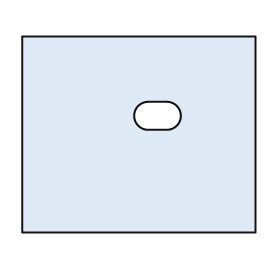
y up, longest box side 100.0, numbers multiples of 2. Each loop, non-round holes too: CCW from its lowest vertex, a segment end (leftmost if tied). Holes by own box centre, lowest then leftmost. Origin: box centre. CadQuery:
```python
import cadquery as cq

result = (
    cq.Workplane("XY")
    .moveTo(-50.0, -42.0)
    .lineTo(50.0, -42.0)
    .lineTo(50.0, 42.0)
    .lineTo(-50.0, 42.0)
    .close()
    .moveTo(4.0, 2.0)
    .lineTo(12.0, 2.0)
    .threePointArc((18.0, 8.0), (12.0, 14.0))
    .lineTo(4.0, 14.0)
    .threePointArc((-2.0, 8.0), (4.0, 2.0))
    .close()
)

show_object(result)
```